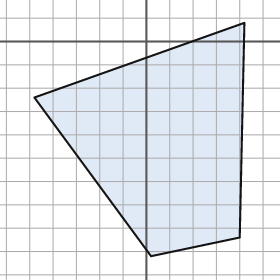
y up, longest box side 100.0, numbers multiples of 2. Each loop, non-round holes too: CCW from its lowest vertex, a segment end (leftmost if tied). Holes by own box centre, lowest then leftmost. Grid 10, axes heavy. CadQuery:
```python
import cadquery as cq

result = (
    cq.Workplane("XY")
    .moveTo(2.0, -92.0)
    .lineTo(40.0, -84.0)
    .lineTo(42.0, 8.0)
    .lineTo(-48.0, -24.0)
    .close()
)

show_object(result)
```